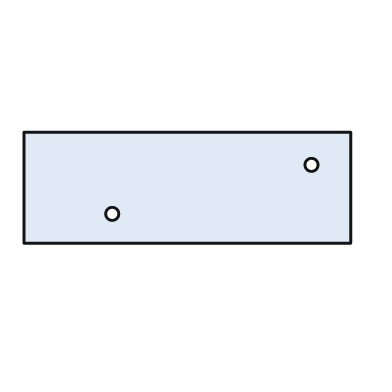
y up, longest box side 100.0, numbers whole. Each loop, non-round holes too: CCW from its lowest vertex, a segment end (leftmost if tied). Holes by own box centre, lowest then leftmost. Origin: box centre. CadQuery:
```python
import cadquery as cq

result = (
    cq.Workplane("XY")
    .moveTo(-50.0, -17.0)
    .lineTo(50.0, -17.0)
    .lineTo(50.0, 17.0)
    .lineTo(-50.0, 17.0)
    .close()
    .moveTo(-23.0, -8.0)
    .circle(2.0)
    .moveTo(38.0, 7.0)
    .circle(2.0)
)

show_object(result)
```